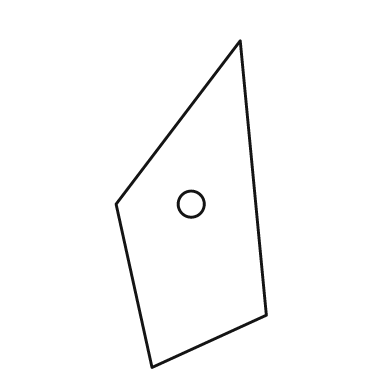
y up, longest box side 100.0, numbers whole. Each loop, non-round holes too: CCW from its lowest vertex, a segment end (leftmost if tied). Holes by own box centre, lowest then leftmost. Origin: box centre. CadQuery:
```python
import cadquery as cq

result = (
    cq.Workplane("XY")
    .moveTo(-12.0, -50.0)
    .lineTo(23.0, -34.0)
    .lineTo(15.0, 50.0)
    .lineTo(-23.0, 0.0)
    .close()
    .moveTo(0.0, 0.0)
    .circle(4.0)
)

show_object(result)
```